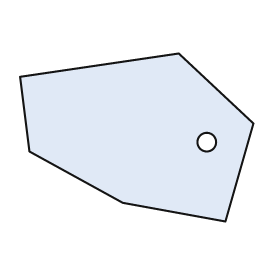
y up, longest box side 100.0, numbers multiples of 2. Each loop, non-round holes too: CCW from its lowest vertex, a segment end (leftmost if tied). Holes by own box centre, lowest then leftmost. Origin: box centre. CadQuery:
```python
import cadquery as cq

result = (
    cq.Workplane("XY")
    .moveTo(38.0, -36.0)
    .lineTo(50.0, 6.0)
    .lineTo(18.0, 36.0)
    .lineTo(-50.0, 26.0)
    .lineTo(-46.0, -6.0)
    .lineTo(-6.0, -28.0)
    .close()
    .moveTo(30.0, -2.0)
    .circle(4.0)
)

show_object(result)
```